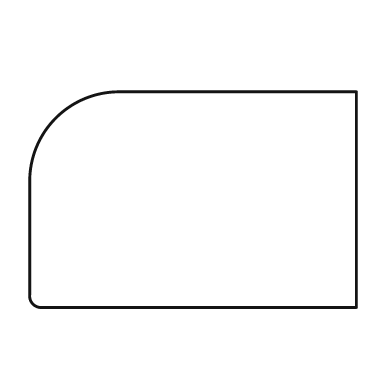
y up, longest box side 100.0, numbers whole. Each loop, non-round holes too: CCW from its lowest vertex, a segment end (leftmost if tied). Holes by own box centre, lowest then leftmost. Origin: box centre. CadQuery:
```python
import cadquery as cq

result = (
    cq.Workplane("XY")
    .moveTo(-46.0, -33.0)
    .lineTo(50.0, -33.0)
    .lineTo(50.0, 33.0)
    .lineTo(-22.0, 33.0)
    .threePointArc((-42.0, 25.0), (-50.0, 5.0))
    .lineTo(-50.0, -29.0)
    .threePointArc((-49.0, -32.0), (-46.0, -33.0))
    .close()
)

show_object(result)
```